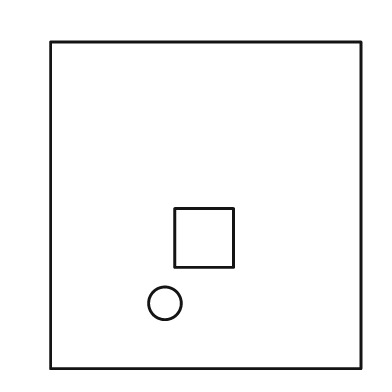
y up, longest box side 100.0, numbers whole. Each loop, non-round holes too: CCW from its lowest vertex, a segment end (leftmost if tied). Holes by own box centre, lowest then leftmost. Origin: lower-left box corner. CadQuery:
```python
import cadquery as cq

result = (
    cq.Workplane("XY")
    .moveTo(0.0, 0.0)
    .lineTo(95.0, 0.0)
    .lineTo(95.0, 100.0)
    .lineTo(0.0, 100.0)
    .close()
    .moveTo(35.0, 20.0)
    .circle(5.0)
    .moveTo(38.0, 31.0)
    .lineTo(56.0, 31.0)
    .lineTo(56.0, 49.0)
    .lineTo(38.0, 49.0)
    .close()
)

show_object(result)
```